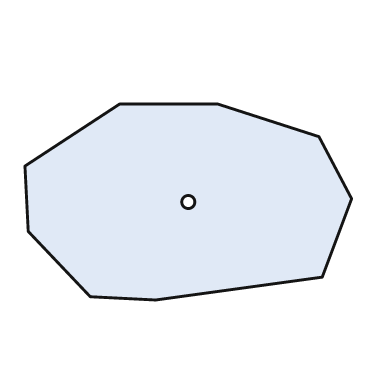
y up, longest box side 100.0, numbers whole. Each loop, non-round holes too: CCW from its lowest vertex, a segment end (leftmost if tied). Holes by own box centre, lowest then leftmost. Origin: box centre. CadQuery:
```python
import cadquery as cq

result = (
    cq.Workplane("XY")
    .moveTo(-10.0, -30.0)
    .lineTo(41.0, -23.0)
    .lineTo(50.0, 1.0)
    .lineTo(40.0, 20.0)
    .lineTo(9.0, 30.0)
    .lineTo(-21.0, 30.0)
    .lineTo(-50.0, 11.0)
    .lineTo(-49.0, -9.0)
    .lineTo(-30.0, -29.0)
    .close()
    .moveTo(0.0, 0.0)
    .circle(2.0)
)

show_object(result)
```